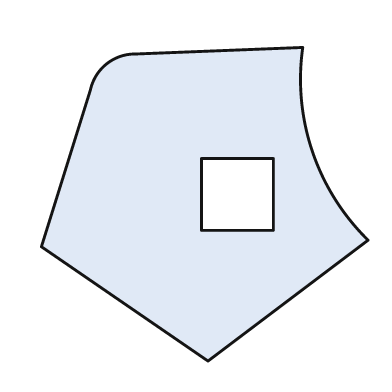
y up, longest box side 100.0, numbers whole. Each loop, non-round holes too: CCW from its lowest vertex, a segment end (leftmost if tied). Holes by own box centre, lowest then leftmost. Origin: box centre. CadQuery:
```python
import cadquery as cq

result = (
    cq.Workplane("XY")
    .moveTo(1.0, -48.0)
    .lineTo(50.0, -11.0)
    .threePointArc((33.0, 16.0), (30.0, 48.0))
    .lineTo(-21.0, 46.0)
    .threePointArc((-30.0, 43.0), (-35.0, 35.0))
    .lineTo(-50.0, -13.0)
    .close()
    .moveTo(-1.0, -8.0)
    .lineTo(21.0, -8.0)
    .lineTo(21.0, 14.0)
    .lineTo(-1.0, 14.0)
    .close()
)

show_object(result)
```